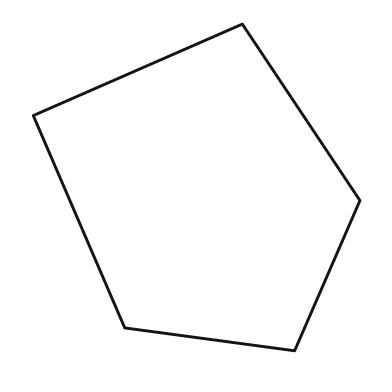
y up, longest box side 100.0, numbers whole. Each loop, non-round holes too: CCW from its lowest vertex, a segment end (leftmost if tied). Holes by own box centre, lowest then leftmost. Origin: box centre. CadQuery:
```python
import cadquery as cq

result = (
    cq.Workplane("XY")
    .moveTo(30.0, -50.0)
    .lineTo(50.0, -4.0)
    .lineTo(14.0, 50.0)
    .lineTo(-50.0, 22.0)
    .lineTo(-22.0, -43.0)
    .close()
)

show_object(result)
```